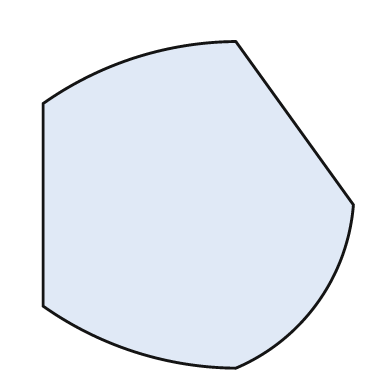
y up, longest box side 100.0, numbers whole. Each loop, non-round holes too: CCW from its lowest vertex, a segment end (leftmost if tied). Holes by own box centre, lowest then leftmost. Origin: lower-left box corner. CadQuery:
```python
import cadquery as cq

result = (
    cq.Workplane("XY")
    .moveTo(59.0, 0.0)
    .threePointArc((84.0, 20.0), (95.0, 50.0))
    .lineTo(59.0, 100.0)
    .threePointArc((28.0, 95.0), (0.0, 81.0))
    .lineTo(0.0, 19.0)
    .threePointArc((28.0, 5.0), (59.0, 0.0))
    .close()
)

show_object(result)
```